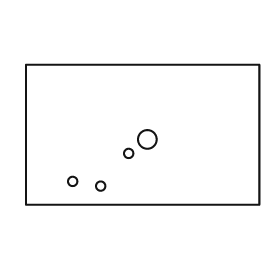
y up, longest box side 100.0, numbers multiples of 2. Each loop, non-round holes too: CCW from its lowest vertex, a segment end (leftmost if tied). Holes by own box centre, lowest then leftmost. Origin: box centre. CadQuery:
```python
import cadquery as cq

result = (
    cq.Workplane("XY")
    .moveTo(-50.0, -30.0)
    .lineTo(50.0, -30.0)
    .lineTo(50.0, 30.0)
    .lineTo(-50.0, 30.0)
    .close()
    .moveTo(-18.0, -22.0)
    .circle(2.0)
    .moveTo(-30.0, -20.0)
    .circle(2.0)
    .moveTo(-6.0, -8.0)
    .circle(2.0)
    .moveTo(2.0, -2.0)
    .circle(4.0)
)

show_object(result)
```